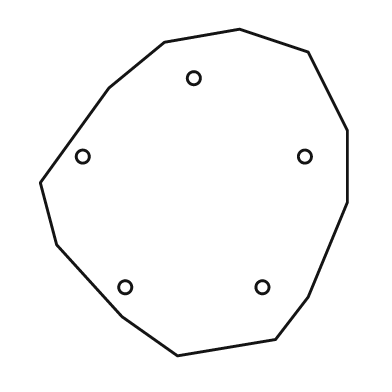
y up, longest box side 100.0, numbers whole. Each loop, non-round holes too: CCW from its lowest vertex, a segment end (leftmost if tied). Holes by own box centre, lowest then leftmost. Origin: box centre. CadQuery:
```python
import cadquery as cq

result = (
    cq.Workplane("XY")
    .moveTo(-5.0, -50.0)
    .lineTo(25.0, -45.0)
    .lineTo(35.0, -32.0)
    .lineTo(47.0, -3.0)
    .lineTo(47.0, 19.0)
    .lineTo(35.0, 43.0)
    .lineTo(14.0, 50.0)
    .lineTo(-9.0, 46.0)
    .lineTo(-26.0, 32.0)
    .lineTo(-47.0, 3.0)
    .lineTo(-42.0, -16.0)
    .lineTo(-22.0, -38.0)
    .close()
    .moveTo(-21.0, -29.0)
    .circle(2.0)
    .moveTo(21.0, -29.0)
    .circle(2.0)
    .moveTo(-34.0, 11.0)
    .circle(2.0)
    .moveTo(34.0, 11.0)
    .circle(2.0)
    .moveTo(0.0, 35.0)
    .circle(2.0)
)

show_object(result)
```